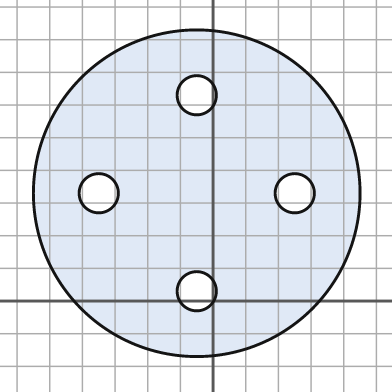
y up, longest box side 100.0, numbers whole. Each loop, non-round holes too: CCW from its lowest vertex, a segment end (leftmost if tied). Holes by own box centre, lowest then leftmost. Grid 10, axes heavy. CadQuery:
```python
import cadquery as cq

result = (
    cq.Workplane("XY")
    .moveTo(-5.0, 33.0)
    .circle(50.0)
    .moveTo(-5.0, 3.0)
    .circle(6.0)
    .moveTo(-35.0, 33.0)
    .circle(6.0)
    .moveTo(25.0, 33.0)
    .circle(6.0)
    .moveTo(-5.0, 63.0)
    .circle(6.0)
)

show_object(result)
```